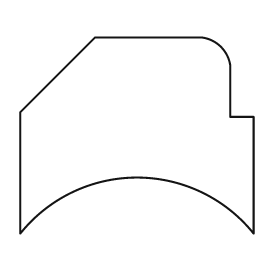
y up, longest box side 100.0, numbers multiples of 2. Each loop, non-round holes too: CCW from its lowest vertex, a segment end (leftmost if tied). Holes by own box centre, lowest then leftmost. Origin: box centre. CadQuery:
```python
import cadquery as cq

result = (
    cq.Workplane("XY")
    .moveTo(-50.0, -42.0)
    .threePointArc((0.0, -18.0), (50.0, -42.0))
    .lineTo(50.0, 8.0)
    .lineTo(40.0, 8.0)
    .lineTo(40.0, 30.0)
    .threePointArc((36.0, 38.0), (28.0, 42.0))
    .lineTo(-18.0, 42.0)
    .lineTo(-50.0, 10.0)
    .close()
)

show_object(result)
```